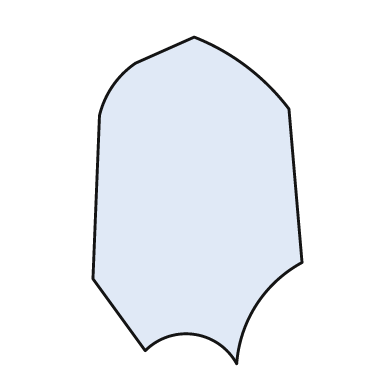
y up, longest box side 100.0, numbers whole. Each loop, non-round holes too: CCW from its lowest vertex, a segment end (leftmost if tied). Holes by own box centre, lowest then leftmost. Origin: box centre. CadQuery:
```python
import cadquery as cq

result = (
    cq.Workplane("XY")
    .moveTo(12.0, -50.0)
    .threePointArc((18.0, -32.0), (32.0, -19.0))
    .lineTo(28.0, 28.0)
    .threePointArc((15.0, 41.0), (-1.0, 50.0))
    .lineTo(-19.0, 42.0)
    .threePointArc((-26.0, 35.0), (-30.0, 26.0))
    .lineTo(-32.0, -24.0)
    .lineTo(-16.0, -46.0)
    .threePointArc((-1.0, -41.0), (12.0, -50.0))
    .close()
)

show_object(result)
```